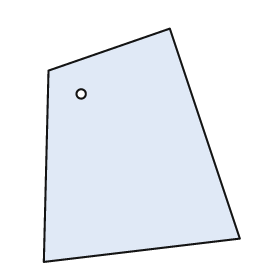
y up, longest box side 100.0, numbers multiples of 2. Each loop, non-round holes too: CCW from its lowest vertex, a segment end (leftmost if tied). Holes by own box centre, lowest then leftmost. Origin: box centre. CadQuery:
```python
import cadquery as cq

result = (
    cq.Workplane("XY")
    .moveTo(-42.0, -50.0)
    .lineTo(42.0, -40.0)
    .lineTo(12.0, 50.0)
    .lineTo(-40.0, 32.0)
    .close()
    .moveTo(-26.0, 22.0)
    .circle(2.0)
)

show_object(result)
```